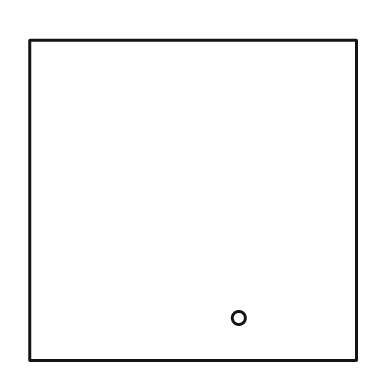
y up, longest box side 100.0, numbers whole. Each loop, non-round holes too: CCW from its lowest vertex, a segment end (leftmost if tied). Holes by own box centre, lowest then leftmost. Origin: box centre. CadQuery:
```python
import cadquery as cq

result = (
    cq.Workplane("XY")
    .moveTo(-50.0, -49.0)
    .lineTo(50.0, -49.0)
    .lineTo(50.0, 49.0)
    .lineTo(-50.0, 49.0)
    .close()
    .moveTo(14.0, -36.0)
    .circle(2.0)
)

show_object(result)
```